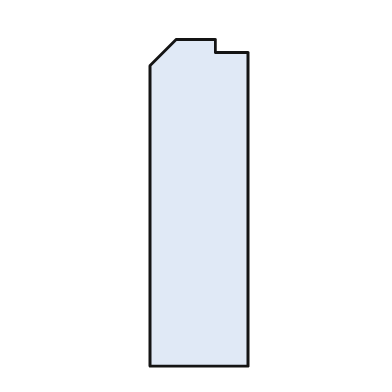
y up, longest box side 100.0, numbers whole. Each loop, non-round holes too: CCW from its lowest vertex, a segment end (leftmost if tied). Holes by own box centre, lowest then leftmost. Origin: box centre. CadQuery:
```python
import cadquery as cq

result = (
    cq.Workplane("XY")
    .moveTo(-15.0, -50.0)
    .lineTo(15.0, -50.0)
    .lineTo(15.0, 46.0)
    .lineTo(5.0, 46.0)
    .lineTo(5.0, 50.0)
    .lineTo(-7.0, 50.0)
    .lineTo(-15.0, 42.0)
    .close()
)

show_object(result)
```